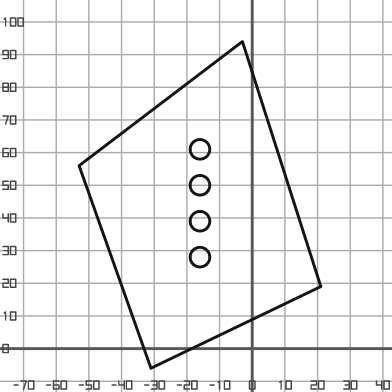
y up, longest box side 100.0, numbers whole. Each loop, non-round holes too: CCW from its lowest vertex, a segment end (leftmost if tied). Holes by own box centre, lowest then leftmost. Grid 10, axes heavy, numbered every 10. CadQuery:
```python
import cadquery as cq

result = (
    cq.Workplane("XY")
    .moveTo(-31.0, -6.0)
    .lineTo(21.0, 19.0)
    .lineTo(-3.0, 94.0)
    .lineTo(-53.0, 56.0)
    .close()
    .moveTo(-16.0, 28.0)
    .circle(3.0)
    .moveTo(-16.0, 39.0)
    .circle(3.0)
    .moveTo(-16.0, 50.0)
    .circle(3.0)
    .moveTo(-16.0, 61.0)
    .circle(3.0)
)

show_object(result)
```